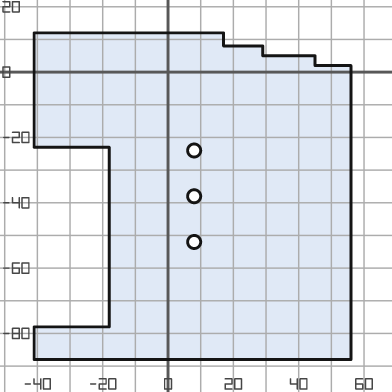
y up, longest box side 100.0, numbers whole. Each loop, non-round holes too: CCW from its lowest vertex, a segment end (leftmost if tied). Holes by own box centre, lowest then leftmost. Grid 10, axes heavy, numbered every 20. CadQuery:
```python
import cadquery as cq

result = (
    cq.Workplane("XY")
    .moveTo(-41.0, -88.0)
    .lineTo(56.0, -88.0)
    .lineTo(56.0, 2.0)
    .lineTo(45.0, 2.0)
    .lineTo(45.0, 5.0)
    .lineTo(29.0, 5.0)
    .lineTo(29.0, 8.0)
    .lineTo(17.0, 8.0)
    .lineTo(17.0, 12.0)
    .lineTo(-41.0, 12.0)
    .lineTo(-41.0, -23.0)
    .lineTo(-18.0, -23.0)
    .lineTo(-18.0, -78.0)
    .lineTo(-41.0, -78.0)
    .close()
    .moveTo(8.0, -52.0)
    .circle(2.0)
    .moveTo(8.0, -38.0)
    .circle(2.0)
    .moveTo(8.0, -24.0)
    .circle(2.0)
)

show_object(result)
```